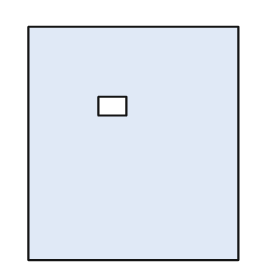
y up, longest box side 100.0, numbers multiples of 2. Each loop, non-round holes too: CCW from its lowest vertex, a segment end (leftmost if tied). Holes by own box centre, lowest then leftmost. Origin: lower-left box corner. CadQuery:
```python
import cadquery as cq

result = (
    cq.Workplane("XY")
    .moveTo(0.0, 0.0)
    .lineTo(90.0, 0.0)
    .lineTo(90.0, 100.0)
    .lineTo(0.0, 100.0)
    .close()
    .moveTo(30.0, 62.0)
    .lineTo(42.0, 62.0)
    .lineTo(42.0, 70.0)
    .lineTo(30.0, 70.0)
    .close()
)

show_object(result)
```